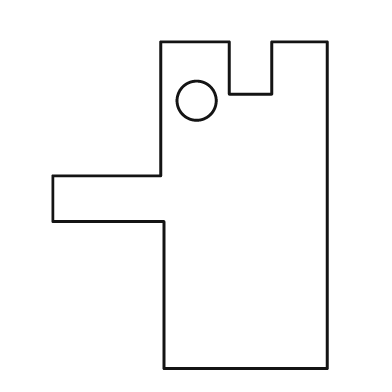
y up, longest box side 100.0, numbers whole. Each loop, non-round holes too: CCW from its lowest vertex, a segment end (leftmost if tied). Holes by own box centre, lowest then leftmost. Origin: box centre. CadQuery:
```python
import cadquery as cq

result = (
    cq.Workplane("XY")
    .moveTo(-8.0, -50.0)
    .lineTo(42.0, -50.0)
    .lineTo(42.0, 50.0)
    .lineTo(25.0, 50.0)
    .lineTo(25.0, 34.0)
    .lineTo(12.0, 34.0)
    .lineTo(12.0, 50.0)
    .lineTo(-9.0, 50.0)
    .lineTo(-9.0, 9.0)
    .lineTo(-42.0, 9.0)
    .lineTo(-42.0, -5.0)
    .lineTo(-8.0, -5.0)
    .close()
    .moveTo(2.0, 32.0)
    .circle(6.0)
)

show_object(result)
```